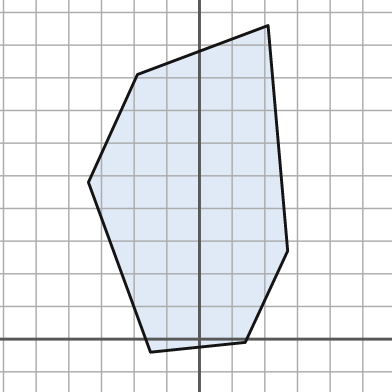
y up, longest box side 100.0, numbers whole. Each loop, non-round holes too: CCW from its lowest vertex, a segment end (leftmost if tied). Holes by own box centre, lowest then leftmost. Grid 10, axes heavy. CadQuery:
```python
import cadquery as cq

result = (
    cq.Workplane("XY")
    .moveTo(-15.0, -4.0)
    .lineTo(14.0, -1.0)
    .lineTo(27.0, 27.0)
    .lineTo(21.0, 96.0)
    .lineTo(-19.0, 81.0)
    .lineTo(-34.0, 48.0)
    .close()
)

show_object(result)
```